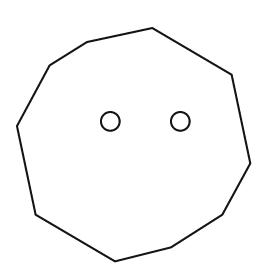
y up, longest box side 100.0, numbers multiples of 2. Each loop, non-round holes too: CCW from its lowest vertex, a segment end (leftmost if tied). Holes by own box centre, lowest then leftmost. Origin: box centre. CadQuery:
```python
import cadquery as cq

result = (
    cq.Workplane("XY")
    .moveTo(-8.0, -50.0)
    .lineTo(16.0, -44.0)
    .lineTo(38.0, -30.0)
    .lineTo(50.0, -8.0)
    .lineTo(42.0, 30.0)
    .lineTo(8.0, 50.0)
    .lineTo(-20.0, 44.0)
    .lineTo(-36.0, 34.0)
    .lineTo(-50.0, 8.0)
    .lineTo(-42.0, -30.0)
    .close()
    .moveTo(-10.0, 10.0)
    .circle(4.0)
    .moveTo(20.0, 10.0)
    .circle(4.0)
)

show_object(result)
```